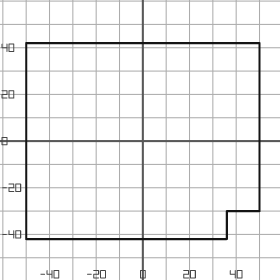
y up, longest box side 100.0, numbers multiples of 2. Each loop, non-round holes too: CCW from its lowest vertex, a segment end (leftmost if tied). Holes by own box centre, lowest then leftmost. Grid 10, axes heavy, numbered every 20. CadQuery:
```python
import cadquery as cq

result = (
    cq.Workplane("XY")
    .moveTo(-50.0, -42.0)
    .lineTo(36.0, -42.0)
    .lineTo(36.0, -30.0)
    .lineTo(50.0, -30.0)
    .lineTo(50.0, 42.0)
    .lineTo(-50.0, 42.0)
    .close()
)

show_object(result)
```